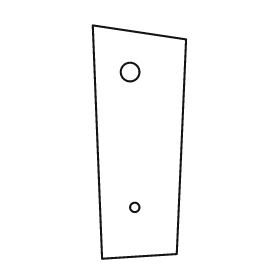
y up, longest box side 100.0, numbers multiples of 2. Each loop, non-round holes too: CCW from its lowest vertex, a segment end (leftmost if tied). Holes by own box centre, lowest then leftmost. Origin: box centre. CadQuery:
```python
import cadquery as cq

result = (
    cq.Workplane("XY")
    .moveTo(-16.0, -50.0)
    .lineTo(16.0, -48.0)
    .lineTo(20.0, 44.0)
    .lineTo(-20.0, 50.0)
    .close()
    .moveTo(-2.0, -28.0)
    .circle(2.0)
    .moveTo(-4.0, 30.0)
    .circle(4.0)
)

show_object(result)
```